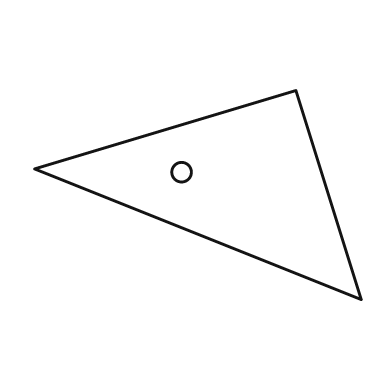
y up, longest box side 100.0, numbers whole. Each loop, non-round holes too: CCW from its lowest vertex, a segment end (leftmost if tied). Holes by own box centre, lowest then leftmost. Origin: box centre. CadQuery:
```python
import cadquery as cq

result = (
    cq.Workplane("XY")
    .moveTo(50.0, -32.0)
    .lineTo(30.0, 32.0)
    .lineTo(-50.0, 8.0)
    .close()
    .moveTo(-5.0, 7.0)
    .circle(3.0)
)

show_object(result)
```